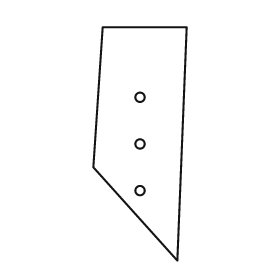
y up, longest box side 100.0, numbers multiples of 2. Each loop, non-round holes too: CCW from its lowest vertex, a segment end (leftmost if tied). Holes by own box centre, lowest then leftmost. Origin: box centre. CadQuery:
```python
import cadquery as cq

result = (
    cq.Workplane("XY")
    .moveTo(16.0, -50.0)
    .lineTo(20.0, 50.0)
    .lineTo(-16.0, 50.0)
    .lineTo(-20.0, -10.0)
    .close()
    .moveTo(0.0, -20.0)
    .circle(2.0)
    .moveTo(0.0, 0.0)
    .circle(2.0)
    .moveTo(0.0, 20.0)
    .circle(2.0)
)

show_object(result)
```